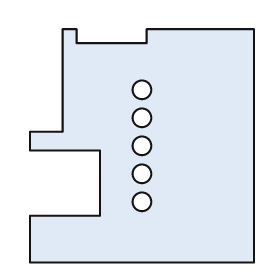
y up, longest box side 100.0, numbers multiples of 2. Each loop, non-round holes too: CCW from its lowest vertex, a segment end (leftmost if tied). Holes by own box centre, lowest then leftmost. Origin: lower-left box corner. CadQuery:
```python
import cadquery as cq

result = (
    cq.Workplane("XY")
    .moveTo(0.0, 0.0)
    .lineTo(96.0, 0.0)
    .lineTo(96.0, 100.0)
    .lineTo(50.0, 100.0)
    .lineTo(50.0, 94.0)
    .lineTo(20.0, 94.0)
    .lineTo(20.0, 100.0)
    .lineTo(14.0, 100.0)
    .lineTo(14.0, 56.0)
    .lineTo(0.0, 56.0)
    .lineTo(0.0, 48.0)
    .lineTo(30.0, 48.0)
    .lineTo(30.0, 20.0)
    .lineTo(0.0, 20.0)
    .close()
    .moveTo(48.0, 26.0)
    .circle(4.0)
    .moveTo(48.0, 38.0)
    .circle(4.0)
    .moveTo(48.0, 50.0)
    .circle(4.0)
    .moveTo(48.0, 62.0)
    .circle(4.0)
    .moveTo(48.0, 74.0)
    .circle(4.0)
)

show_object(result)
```